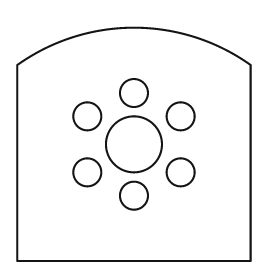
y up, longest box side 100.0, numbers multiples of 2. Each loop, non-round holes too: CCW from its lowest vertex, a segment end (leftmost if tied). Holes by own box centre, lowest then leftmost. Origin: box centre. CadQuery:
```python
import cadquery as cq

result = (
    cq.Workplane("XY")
    .moveTo(-50.0, -50.0)
    .lineTo(50.0, -50.0)
    .lineTo(50.0, 34.0)
    .threePointArc((0.0, 50.0), (-50.0, 34.0))
    .close()
    .moveTo(0.0, -22.0)
    .circle(6.0)
    .moveTo(-20.0, -12.0)
    .circle(6.0)
    .moveTo(20.0, -12.0)
    .circle(6.0)
    .moveTo(0.0, 0.0)
    .circle(12.0)
    .moveTo(-20.0, 12.0)
    .circle(6.0)
    .moveTo(20.0, 12.0)
    .circle(6.0)
    .moveTo(0.0, 22.0)
    .circle(6.0)
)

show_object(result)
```